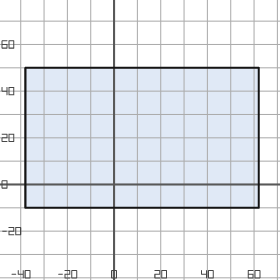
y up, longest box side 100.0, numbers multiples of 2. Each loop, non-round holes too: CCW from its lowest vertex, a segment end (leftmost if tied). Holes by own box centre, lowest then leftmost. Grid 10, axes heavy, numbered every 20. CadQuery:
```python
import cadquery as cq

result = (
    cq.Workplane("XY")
    .moveTo(-38.0, -10.0)
    .lineTo(62.0, -10.0)
    .lineTo(62.0, 50.0)
    .lineTo(-38.0, 50.0)
    .close()
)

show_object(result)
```